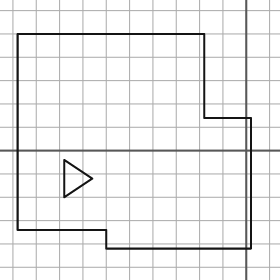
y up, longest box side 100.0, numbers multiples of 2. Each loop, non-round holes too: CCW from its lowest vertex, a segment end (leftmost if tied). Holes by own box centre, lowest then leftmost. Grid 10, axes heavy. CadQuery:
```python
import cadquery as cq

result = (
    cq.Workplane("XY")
    .moveTo(-60.0, -42.0)
    .lineTo(2.0, -42.0)
    .lineTo(2.0, 14.0)
    .lineTo(-18.0, 14.0)
    .lineTo(-18.0, 50.0)
    .lineTo(-98.0, 50.0)
    .lineTo(-98.0, -34.0)
    .lineTo(-60.0, -34.0)
    .close()
    .moveTo(-78.0, -20.0)
    .lineTo(-66.0, -12.0)
    .lineTo(-78.0, -4.0)
    .close()
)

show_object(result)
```